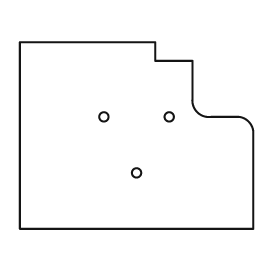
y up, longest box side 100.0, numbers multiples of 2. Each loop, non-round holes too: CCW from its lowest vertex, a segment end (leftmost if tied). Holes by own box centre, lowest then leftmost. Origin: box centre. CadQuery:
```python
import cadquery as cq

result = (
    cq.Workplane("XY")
    .moveTo(-50.0, -40.0)
    .lineTo(50.0, -40.0)
    .lineTo(50.0, 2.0)
    .threePointArc((48.0, 6.0), (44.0, 8.0))
    .lineTo(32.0, 8.0)
    .threePointArc((26.0, 10.0), (24.0, 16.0))
    .lineTo(24.0, 32.0)
    .lineTo(8.0, 32.0)
    .lineTo(8.0, 40.0)
    .lineTo(-50.0, 40.0)
    .close()
    .moveTo(0.0, -16.0)
    .circle(2.0)
    .moveTo(-14.0, 8.0)
    .circle(2.0)
    .moveTo(14.0, 8.0)
    .circle(2.0)
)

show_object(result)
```